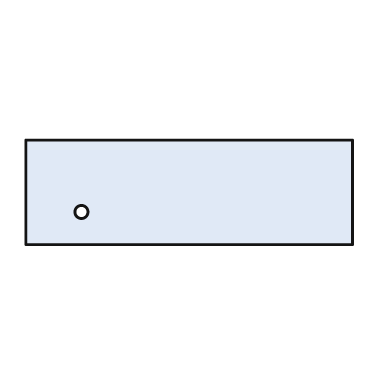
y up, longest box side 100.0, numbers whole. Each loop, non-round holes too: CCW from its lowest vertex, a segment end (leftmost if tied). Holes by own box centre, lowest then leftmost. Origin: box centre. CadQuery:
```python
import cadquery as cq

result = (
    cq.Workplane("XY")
    .moveTo(-50.0, -16.0)
    .lineTo(50.0, -16.0)
    .lineTo(50.0, 16.0)
    .lineTo(-50.0, 16.0)
    .close()
    .moveTo(-33.0, -6.0)
    .circle(2.0)
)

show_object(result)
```